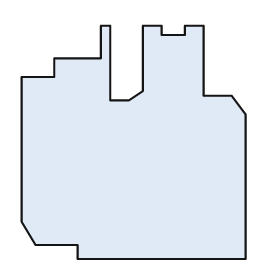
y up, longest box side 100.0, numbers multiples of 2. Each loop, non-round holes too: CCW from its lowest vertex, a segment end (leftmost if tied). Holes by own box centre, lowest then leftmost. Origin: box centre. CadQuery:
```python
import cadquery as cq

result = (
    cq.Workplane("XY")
    .moveTo(-24.0, -50.0)
    .lineTo(48.0, -50.0)
    .lineTo(48.0, 12.0)
    .lineTo(42.0, 20.0)
    .lineTo(30.0, 20.0)
    .lineTo(30.0, 50.0)
    .lineTo(22.0, 50.0)
    .lineTo(22.0, 46.0)
    .lineTo(12.0, 46.0)
    .lineTo(12.0, 50.0)
    .lineTo(4.0, 50.0)
    .lineTo(4.0, 22.0)
    .lineTo(-2.0, 18.0)
    .lineTo(-10.0, 18.0)
    .lineTo(-10.0, 50.0)
    .lineTo(-14.0, 50.0)
    .lineTo(-14.0, 36.0)
    .lineTo(-34.0, 36.0)
    .lineTo(-34.0, 28.0)
    .lineTo(-48.0, 28.0)
    .lineTo(-48.0, -34.0)
    .lineTo(-42.0, -44.0)
    .lineTo(-24.0, -44.0)
    .close()
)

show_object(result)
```